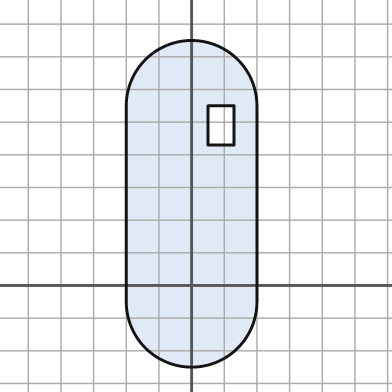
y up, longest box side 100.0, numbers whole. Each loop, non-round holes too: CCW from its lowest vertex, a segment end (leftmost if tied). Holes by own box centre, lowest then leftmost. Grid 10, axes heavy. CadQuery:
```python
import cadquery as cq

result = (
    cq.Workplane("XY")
    .moveTo(-20.0, -5.0)
    .threePointArc((0.0, -25.0), (20.0, -5.0))
    .lineTo(20.0, 55.0)
    .threePointArc((0.0, 75.0), (-20.0, 55.0))
    .close()
    .moveTo(5.0, 43.0)
    .lineTo(13.0, 43.0)
    .lineTo(13.0, 55.0)
    .lineTo(5.0, 55.0)
    .close()
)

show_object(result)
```